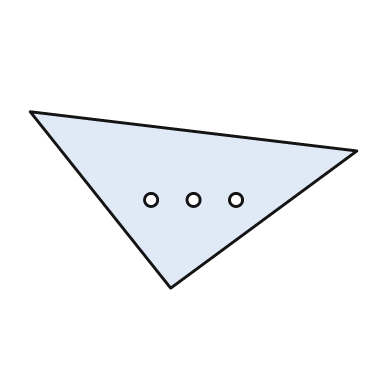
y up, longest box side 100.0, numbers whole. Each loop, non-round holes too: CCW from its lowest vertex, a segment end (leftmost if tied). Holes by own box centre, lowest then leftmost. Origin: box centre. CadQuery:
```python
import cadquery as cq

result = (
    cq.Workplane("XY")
    .moveTo(-7.0, -27.0)
    .lineTo(50.0, 15.0)
    .lineTo(-50.0, 27.0)
    .close()
    .moveTo(-13.0, 0.0)
    .circle(2.0)
    .moveTo(0.0, 0.0)
    .circle(2.0)
    .moveTo(13.0, 0.0)
    .circle(2.0)
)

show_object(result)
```